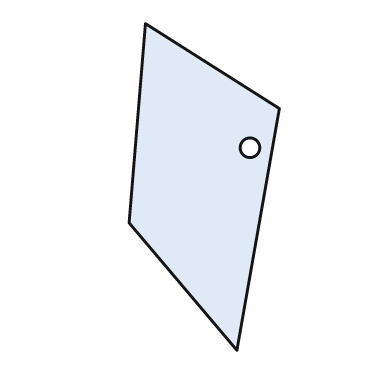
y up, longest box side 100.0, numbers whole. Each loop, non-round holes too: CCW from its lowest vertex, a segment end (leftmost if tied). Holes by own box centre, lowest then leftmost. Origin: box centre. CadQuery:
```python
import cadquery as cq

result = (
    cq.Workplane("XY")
    .moveTo(10.0, -50.0)
    .lineTo(23.0, 24.0)
    .lineTo(-18.0, 50.0)
    .lineTo(-23.0, -11.0)
    .close()
    .moveTo(14.0, 12.0)
    .circle(3.0)
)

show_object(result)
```